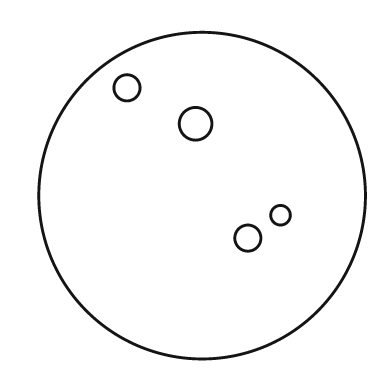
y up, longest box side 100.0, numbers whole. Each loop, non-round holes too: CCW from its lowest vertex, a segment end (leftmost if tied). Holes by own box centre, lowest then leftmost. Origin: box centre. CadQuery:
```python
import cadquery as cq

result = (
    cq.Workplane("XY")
    .moveTo(0.0, 0.0)
    .circle(50.0)
    .moveTo(14.0, -13.0)
    .circle(4.0)
    .moveTo(24.0, -6.0)
    .circle(3.0)
    .moveTo(-2.0, 22.0)
    .circle(5.0)
    .moveTo(-23.0, 33.0)
    .circle(4.0)
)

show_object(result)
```